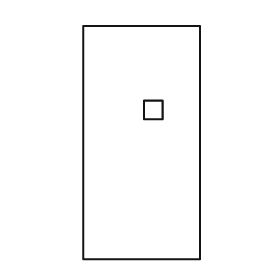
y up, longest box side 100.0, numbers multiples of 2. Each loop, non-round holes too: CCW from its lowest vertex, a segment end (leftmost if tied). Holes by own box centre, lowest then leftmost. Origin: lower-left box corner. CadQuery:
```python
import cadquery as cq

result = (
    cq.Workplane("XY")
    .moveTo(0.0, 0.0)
    .lineTo(50.0, 0.0)
    .lineTo(50.0, 100.0)
    .lineTo(0.0, 100.0)
    .close()
    .moveTo(26.0, 60.0)
    .lineTo(34.0, 60.0)
    .lineTo(34.0, 68.0)
    .lineTo(26.0, 68.0)
    .close()
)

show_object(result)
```